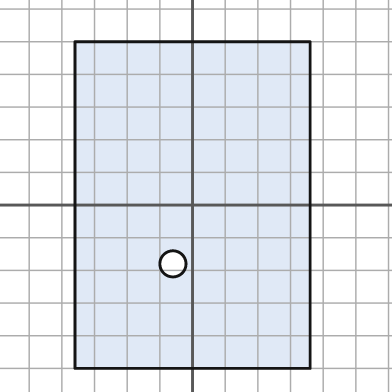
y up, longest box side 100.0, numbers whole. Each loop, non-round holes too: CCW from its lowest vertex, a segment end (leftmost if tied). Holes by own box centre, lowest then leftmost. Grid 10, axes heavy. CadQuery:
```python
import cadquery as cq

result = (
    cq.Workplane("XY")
    .moveTo(-36.0, -50.0)
    .lineTo(36.0, -50.0)
    .lineTo(36.0, 50.0)
    .lineTo(-36.0, 50.0)
    .close()
    .moveTo(-6.0, -18.0)
    .circle(4.0)
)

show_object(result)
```